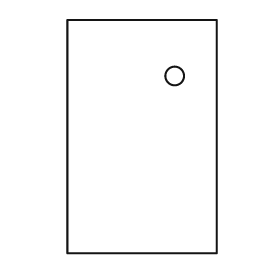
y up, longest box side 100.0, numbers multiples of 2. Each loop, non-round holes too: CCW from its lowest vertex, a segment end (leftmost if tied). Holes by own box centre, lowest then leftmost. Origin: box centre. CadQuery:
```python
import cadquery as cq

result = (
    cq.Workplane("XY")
    .moveTo(-32.0, -50.0)
    .lineTo(32.0, -50.0)
    .lineTo(32.0, 50.0)
    .lineTo(-32.0, 50.0)
    .close()
    .moveTo(14.0, 26.0)
    .circle(4.0)
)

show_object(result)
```